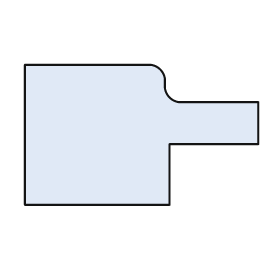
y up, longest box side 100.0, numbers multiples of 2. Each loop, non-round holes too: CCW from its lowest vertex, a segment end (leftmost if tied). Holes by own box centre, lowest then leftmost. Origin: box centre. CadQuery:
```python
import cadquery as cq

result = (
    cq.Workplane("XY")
    .moveTo(-50.0, -30.0)
    .lineTo(12.0, -30.0)
    .lineTo(12.0, -4.0)
    .lineTo(50.0, -4.0)
    .lineTo(50.0, 14.0)
    .lineTo(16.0, 14.0)
    .threePointArc((12.0, 16.0), (10.0, 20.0))
    .lineTo(10.0, 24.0)
    .threePointArc((8.0, 28.0), (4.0, 30.0))
    .lineTo(-50.0, 30.0)
    .close()
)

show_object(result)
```